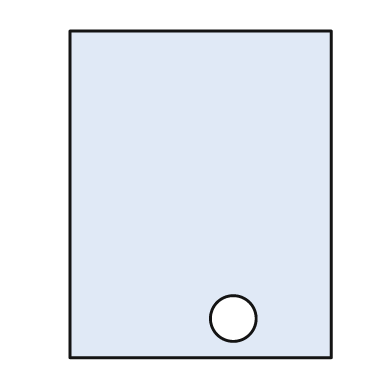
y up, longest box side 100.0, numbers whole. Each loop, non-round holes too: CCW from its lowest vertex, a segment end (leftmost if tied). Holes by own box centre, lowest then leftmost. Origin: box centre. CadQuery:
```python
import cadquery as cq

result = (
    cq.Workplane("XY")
    .moveTo(-40.0, -50.0)
    .lineTo(40.0, -50.0)
    .lineTo(40.0, 50.0)
    .lineTo(-40.0, 50.0)
    .close()
    .moveTo(10.0, -38.0)
    .circle(7.0)
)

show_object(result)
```